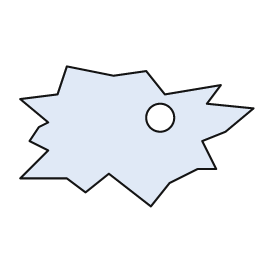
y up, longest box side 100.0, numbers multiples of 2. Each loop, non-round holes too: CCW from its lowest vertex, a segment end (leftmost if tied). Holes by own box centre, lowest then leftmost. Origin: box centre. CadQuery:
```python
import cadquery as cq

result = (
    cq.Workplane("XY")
    .moveTo(6.0, -30.0)
    .lineTo(14.0, -20.0)
    .lineTo(26.0, -14.0)
    .lineTo(34.0, -14.0)
    .lineTo(28.0, -2.0)
    .lineTo(38.0, 2.0)
    .lineTo(50.0, 12.0)
    .lineTo(30.0, 14.0)
    .lineTo(36.0, 22.0)
    .lineTo(12.0, 18.0)
    .lineTo(4.0, 28.0)
    .lineTo(-10.0, 26.0)
    .lineTo(-30.0, 30.0)
    .lineTo(-34.0, 18.0)
    .lineTo(-50.0, 16.0)
    .lineTo(-38.0, 6.0)
    .lineTo(-42.0, 4.0)
    .lineTo(-46.0, -2.0)
    .lineTo(-38.0, -6.0)
    .lineTo(-50.0, -18.0)
    .lineTo(-30.0, -18.0)
    .lineTo(-22.0, -24.0)
    .lineTo(-12.0, -16.0)
    .close()
    .moveTo(10.0, 8.0)
    .circle(6.0)
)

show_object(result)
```